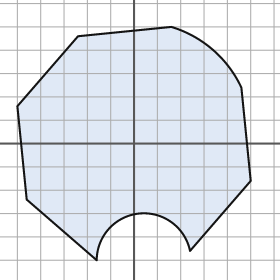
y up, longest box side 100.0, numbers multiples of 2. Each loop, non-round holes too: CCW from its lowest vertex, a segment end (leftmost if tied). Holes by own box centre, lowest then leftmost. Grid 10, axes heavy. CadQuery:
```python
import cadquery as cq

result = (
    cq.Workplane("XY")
    .moveTo(-16.0, -50.0)
    .threePointArc((2.0, -30.0), (24.0, -46.0))
    .lineTo(50.0, -16.0)
    .lineTo(46.0, 24.0)
    .threePointArc((34.0, 40.0), (16.0, 50.0))
    .lineTo(-24.0, 46.0)
    .lineTo(-50.0, 16.0)
    .lineTo(-46.0, -24.0)
    .close()
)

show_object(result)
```